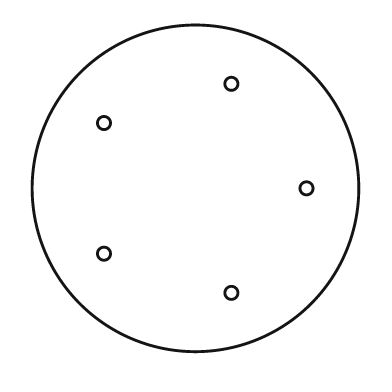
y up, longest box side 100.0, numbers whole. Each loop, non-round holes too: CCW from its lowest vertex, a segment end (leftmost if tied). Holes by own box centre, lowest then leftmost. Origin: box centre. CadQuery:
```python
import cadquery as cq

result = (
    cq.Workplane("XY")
    .moveTo(0.0, 0.0)
    .circle(50.0)
    .moveTo(11.0, -32.0)
    .circle(2.0)
    .moveTo(-28.0, -20.0)
    .circle(2.0)
    .moveTo(34.0, 0.0)
    .circle(2.0)
    .moveTo(-28.0, 20.0)
    .circle(2.0)
    .moveTo(11.0, 32.0)
    .circle(2.0)
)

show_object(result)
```